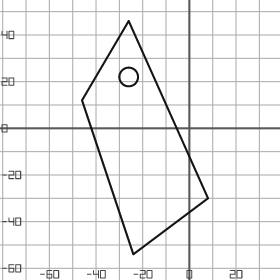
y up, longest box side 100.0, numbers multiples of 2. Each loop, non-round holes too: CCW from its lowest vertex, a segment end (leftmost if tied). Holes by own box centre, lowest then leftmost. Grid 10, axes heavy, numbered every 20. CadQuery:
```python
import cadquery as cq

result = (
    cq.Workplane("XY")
    .moveTo(-24.0, -54.0)
    .lineTo(8.0, -30.0)
    .lineTo(-26.0, 46.0)
    .lineTo(-46.0, 12.0)
    .close()
    .moveTo(-26.0, 22.0)
    .circle(4.0)
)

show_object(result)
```